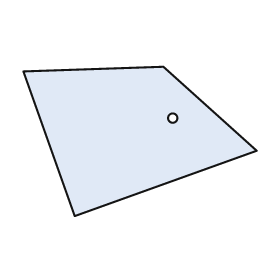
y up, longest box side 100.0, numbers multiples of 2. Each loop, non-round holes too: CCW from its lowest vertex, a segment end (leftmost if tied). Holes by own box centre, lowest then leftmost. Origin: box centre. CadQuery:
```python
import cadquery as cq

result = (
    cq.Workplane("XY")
    .moveTo(-28.0, -32.0)
    .lineTo(50.0, -4.0)
    .lineTo(10.0, 32.0)
    .lineTo(-50.0, 30.0)
    .close()
    .moveTo(14.0, 10.0)
    .circle(2.0)
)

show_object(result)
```